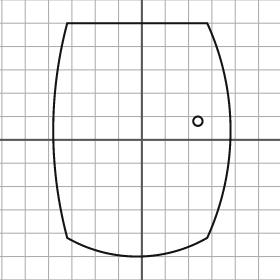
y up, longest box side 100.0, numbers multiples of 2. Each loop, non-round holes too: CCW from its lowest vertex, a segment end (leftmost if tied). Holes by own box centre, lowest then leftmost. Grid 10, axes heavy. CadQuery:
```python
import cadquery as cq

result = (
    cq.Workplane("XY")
    .moveTo(-32.0, -42.0)
    .threePointArc((-2.0, -50.0), (28.0, -42.0))
    .threePointArc((38.0, 4.0), (28.0, 50.0))
    .lineTo(-32.0, 50.0)
    .threePointArc((-38.0, 4.0), (-32.0, -42.0))
    .close()
    .moveTo(24.0, 8.0)
    .circle(2.0)
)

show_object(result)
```